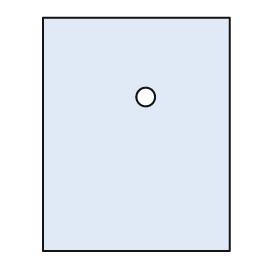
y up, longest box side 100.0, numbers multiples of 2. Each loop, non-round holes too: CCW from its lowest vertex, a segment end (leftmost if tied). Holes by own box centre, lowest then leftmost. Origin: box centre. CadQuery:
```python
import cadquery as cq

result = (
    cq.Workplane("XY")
    .moveTo(-40.0, -50.0)
    .lineTo(40.0, -50.0)
    .lineTo(40.0, 50.0)
    .lineTo(-40.0, 50.0)
    .close()
    .moveTo(4.0, 16.0)
    .circle(4.0)
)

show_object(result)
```